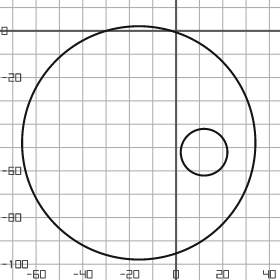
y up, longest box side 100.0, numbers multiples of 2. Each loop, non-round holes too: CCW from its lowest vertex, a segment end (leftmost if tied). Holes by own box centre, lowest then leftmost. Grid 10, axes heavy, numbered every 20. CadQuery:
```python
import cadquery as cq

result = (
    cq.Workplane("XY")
    .moveTo(-16.0, -48.0)
    .circle(50.0)
    .moveTo(12.0, -52.0)
    .circle(10.0)
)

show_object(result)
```